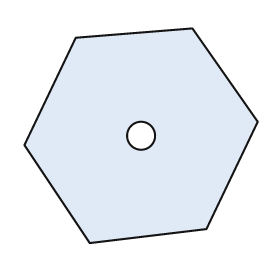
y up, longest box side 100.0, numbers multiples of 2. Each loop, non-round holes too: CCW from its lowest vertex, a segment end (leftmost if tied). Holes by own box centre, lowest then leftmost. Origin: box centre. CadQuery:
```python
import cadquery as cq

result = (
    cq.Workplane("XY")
    .moveTo(-22.0, -46.0)
    .lineTo(28.0, -40.0)
    .lineTo(50.0, 6.0)
    .lineTo(22.0, 46.0)
    .lineTo(-28.0, 42.0)
    .lineTo(-50.0, -4.0)
    .close()
    .moveTo(0.0, 0.0)
    .circle(6.0)
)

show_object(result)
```